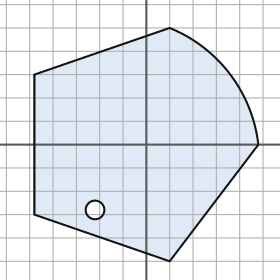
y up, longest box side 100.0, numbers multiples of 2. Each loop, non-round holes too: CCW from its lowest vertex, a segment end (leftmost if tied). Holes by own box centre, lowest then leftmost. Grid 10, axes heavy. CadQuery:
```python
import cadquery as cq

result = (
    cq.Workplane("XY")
    .moveTo(10.0, -50.0)
    .lineTo(48.0, 0.0)
    .threePointArc((36.0, 30.0), (10.0, 50.0))
    .lineTo(-48.0, 30.0)
    .lineTo(-48.0, -30.0)
    .close()
    .moveTo(-22.0, -28.0)
    .circle(4.0)
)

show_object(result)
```